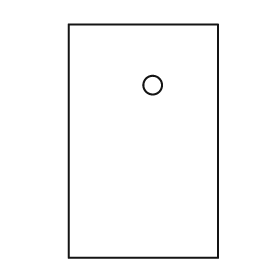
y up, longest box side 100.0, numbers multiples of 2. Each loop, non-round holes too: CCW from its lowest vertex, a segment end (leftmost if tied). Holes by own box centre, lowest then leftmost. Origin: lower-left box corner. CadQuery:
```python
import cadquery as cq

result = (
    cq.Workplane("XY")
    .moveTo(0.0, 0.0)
    .lineTo(64.0, 0.0)
    .lineTo(64.0, 100.0)
    .lineTo(0.0, 100.0)
    .close()
    .moveTo(36.0, 74.0)
    .circle(4.0)
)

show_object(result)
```